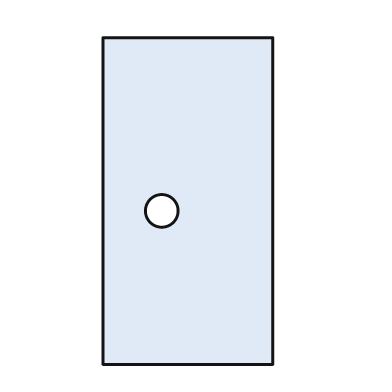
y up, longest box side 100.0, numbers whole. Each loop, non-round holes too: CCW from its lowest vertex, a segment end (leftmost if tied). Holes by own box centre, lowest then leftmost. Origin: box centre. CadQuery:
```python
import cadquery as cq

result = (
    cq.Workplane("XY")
    .moveTo(-26.0, -50.0)
    .lineTo(26.0, -50.0)
    .lineTo(26.0, 50.0)
    .lineTo(-26.0, 50.0)
    .close()
    .moveTo(-8.0, -3.0)
    .circle(5.0)
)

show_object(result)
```